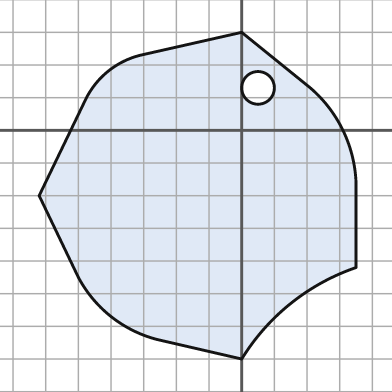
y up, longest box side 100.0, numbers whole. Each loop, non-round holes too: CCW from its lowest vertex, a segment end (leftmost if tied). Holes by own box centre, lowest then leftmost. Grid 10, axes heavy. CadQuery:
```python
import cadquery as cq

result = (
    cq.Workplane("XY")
    .moveTo(0.0, -70.0)
    .threePointArc((15.0, -53.0), (35.0, -42.0))
    .lineTo(35.0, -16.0)
    .threePointArc((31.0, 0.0), (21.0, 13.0))
    .lineTo(0.0, 30.0)
    .lineTo(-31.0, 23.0)
    .threePointArc((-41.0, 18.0), (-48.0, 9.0))
    .lineTo(-62.0, -20.0)
    .lineTo(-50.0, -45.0)
    .threePointArc((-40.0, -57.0), (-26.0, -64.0))
    .close()
    .moveTo(5.0, 13.0)
    .circle(5.0)
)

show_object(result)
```